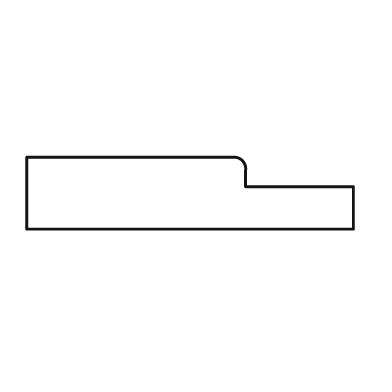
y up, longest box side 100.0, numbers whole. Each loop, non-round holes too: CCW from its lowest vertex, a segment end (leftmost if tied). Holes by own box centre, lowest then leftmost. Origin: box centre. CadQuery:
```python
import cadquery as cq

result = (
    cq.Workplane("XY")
    .moveTo(-50.0, -11.0)
    .lineTo(50.0, -11.0)
    .lineTo(50.0, 2.0)
    .lineTo(17.0, 2.0)
    .lineTo(17.0, 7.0)
    .threePointArc((16.0, 10.0), (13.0, 11.0))
    .lineTo(-50.0, 11.0)
    .close()
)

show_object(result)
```